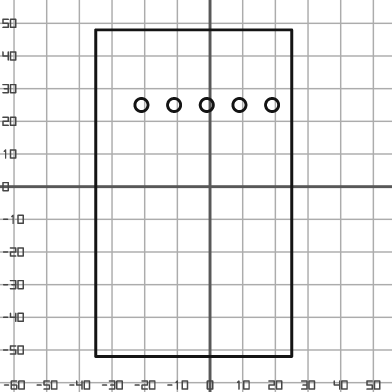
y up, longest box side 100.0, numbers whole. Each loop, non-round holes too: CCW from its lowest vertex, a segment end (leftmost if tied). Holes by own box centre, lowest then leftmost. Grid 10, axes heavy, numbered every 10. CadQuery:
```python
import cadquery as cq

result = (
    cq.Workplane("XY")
    .moveTo(-35.0, -52.0)
    .lineTo(25.0, -52.0)
    .lineTo(25.0, 48.0)
    .lineTo(-35.0, 48.0)
    .close()
    .moveTo(-21.0, 25.0)
    .circle(2.0)
    .moveTo(-11.0, 25.0)
    .circle(2.0)
    .moveTo(-1.0, 25.0)
    .circle(2.0)
    .moveTo(9.0, 25.0)
    .circle(2.0)
    .moveTo(19.0, 25.0)
    .circle(2.0)
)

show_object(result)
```